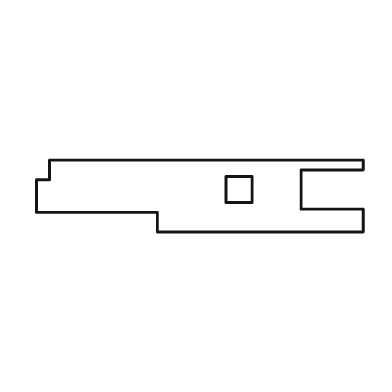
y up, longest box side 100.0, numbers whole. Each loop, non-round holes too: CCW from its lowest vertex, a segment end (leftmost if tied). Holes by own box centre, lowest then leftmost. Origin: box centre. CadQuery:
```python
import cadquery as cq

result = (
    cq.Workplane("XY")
    .moveTo(-13.0, -11.0)
    .lineTo(50.0, -11.0)
    .lineTo(50.0, -4.0)
    .lineTo(31.0, -4.0)
    .lineTo(31.0, 8.0)
    .lineTo(50.0, 8.0)
    .lineTo(50.0, 11.0)
    .lineTo(-46.0, 11.0)
    .lineTo(-46.0, 5.0)
    .lineTo(-50.0, 5.0)
    .lineTo(-50.0, -5.0)
    .lineTo(-13.0, -5.0)
    .close()
    .moveTo(8.0, -2.0)
    .lineTo(16.0, -2.0)
    .lineTo(16.0, 6.0)
    .lineTo(8.0, 6.0)
    .close()
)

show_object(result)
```